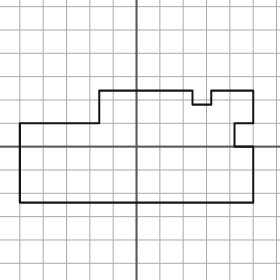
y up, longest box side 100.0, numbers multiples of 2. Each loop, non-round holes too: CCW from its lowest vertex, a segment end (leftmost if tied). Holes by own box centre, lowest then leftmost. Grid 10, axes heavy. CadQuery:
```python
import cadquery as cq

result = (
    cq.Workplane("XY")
    .moveTo(-50.0, -24.0)
    .lineTo(50.0, -24.0)
    .lineTo(50.0, 0.0)
    .lineTo(42.0, 0.0)
    .lineTo(42.0, 10.0)
    .lineTo(50.0, 10.0)
    .lineTo(50.0, 24.0)
    .lineTo(32.0, 24.0)
    .lineTo(32.0, 18.0)
    .lineTo(24.0, 18.0)
    .lineTo(24.0, 24.0)
    .lineTo(-16.0, 24.0)
    .lineTo(-16.0, 10.0)
    .lineTo(-50.0, 10.0)
    .close()
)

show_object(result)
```